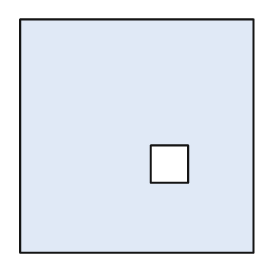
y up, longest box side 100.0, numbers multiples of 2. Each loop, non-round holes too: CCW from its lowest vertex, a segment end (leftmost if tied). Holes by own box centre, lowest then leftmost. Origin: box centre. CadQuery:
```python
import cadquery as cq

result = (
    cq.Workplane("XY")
    .moveTo(-50.0, -50.0)
    .lineTo(50.0, -50.0)
    .lineTo(50.0, 50.0)
    .lineTo(-50.0, 50.0)
    .close()
    .moveTo(6.0, -20.0)
    .lineTo(22.0, -20.0)
    .lineTo(22.0, -4.0)
    .lineTo(6.0, -4.0)
    .close()
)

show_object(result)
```